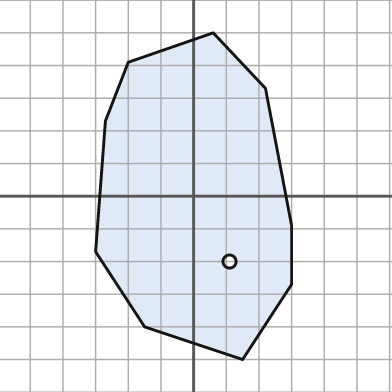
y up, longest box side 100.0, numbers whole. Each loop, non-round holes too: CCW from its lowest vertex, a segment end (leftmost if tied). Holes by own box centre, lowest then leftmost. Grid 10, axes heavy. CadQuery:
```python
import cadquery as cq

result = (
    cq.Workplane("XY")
    .moveTo(15.0, -50.0)
    .lineTo(30.0, -27.0)
    .lineTo(30.0, -9.0)
    .lineTo(22.0, 33.0)
    .lineTo(6.0, 50.0)
    .lineTo(-20.0, 41.0)
    .lineTo(-27.0, 23.0)
    .lineTo(-30.0, -17.0)
    .lineTo(-15.0, -40.0)
    .close()
    .moveTo(11.0, -20.0)
    .circle(2.0)
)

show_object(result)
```